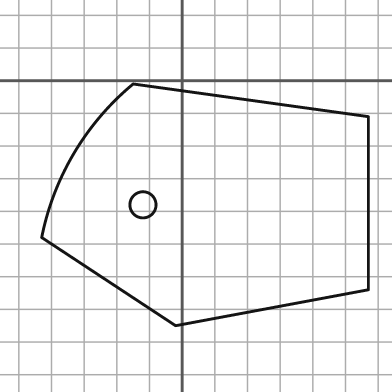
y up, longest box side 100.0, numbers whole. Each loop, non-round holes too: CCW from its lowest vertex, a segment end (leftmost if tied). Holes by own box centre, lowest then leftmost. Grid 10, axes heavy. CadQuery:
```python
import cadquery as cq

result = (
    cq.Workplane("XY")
    .moveTo(-2.0, -75.0)
    .lineTo(57.0, -64.0)
    .lineTo(57.0, -11.0)
    .lineTo(-15.0, -1.0)
    .threePointArc((-33.0, -22.0), (-43.0, -48.0))
    .close()
    .moveTo(-12.0, -38.0)
    .circle(4.0)
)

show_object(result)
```